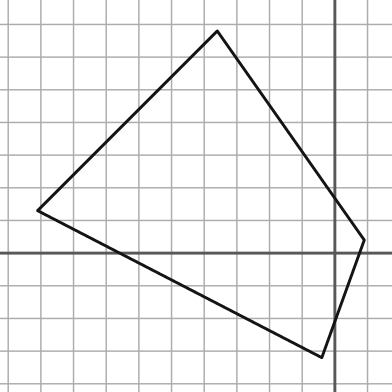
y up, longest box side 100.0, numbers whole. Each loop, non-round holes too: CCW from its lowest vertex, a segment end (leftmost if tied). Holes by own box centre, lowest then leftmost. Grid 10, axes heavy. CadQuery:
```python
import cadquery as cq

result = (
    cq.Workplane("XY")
    .moveTo(-4.0, -32.0)
    .lineTo(9.0, 4.0)
    .lineTo(-36.0, 68.0)
    .lineTo(-91.0, 13.0)
    .close()
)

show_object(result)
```